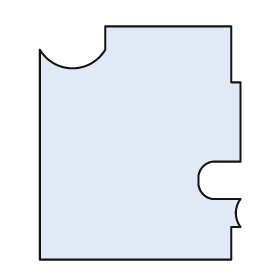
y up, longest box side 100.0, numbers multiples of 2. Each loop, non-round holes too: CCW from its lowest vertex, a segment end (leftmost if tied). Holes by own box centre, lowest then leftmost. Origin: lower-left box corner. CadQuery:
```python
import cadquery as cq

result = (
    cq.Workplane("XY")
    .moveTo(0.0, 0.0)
    .lineTo(82.0, 0.0)
    .lineTo(82.0, 14.0)
    .lineTo(86.0, 14.0)
    .threePointArc((84.0, 20.0), (86.0, 26.0))
    .lineTo(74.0, 26.0)
    .threePointArc((70.0, 28.0), (68.0, 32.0))
    .lineTo(68.0, 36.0)
    .threePointArc((70.0, 40.0), (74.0, 42.0))
    .lineTo(86.0, 42.0)
    .lineTo(86.0, 76.0)
    .lineTo(82.0, 76.0)
    .lineTo(82.0, 100.0)
    .lineTo(28.0, 100.0)
    .lineTo(28.0, 90.0)
    .threePointArc((14.0, 82.0), (0.0, 90.0))
    .close()
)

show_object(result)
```